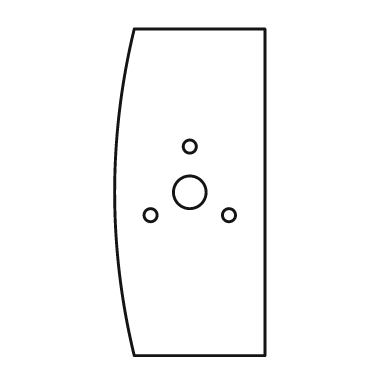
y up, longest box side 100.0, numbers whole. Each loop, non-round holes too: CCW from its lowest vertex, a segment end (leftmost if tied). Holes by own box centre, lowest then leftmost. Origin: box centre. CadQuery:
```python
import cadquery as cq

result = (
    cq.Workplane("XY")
    .moveTo(-17.0, -50.0)
    .lineTo(23.0, -50.0)
    .lineTo(23.0, 50.0)
    .lineTo(-17.0, 50.0)
    .threePointArc((-23.0, 0.0), (-17.0, -50.0))
    .close()
    .moveTo(-12.0, -7.0)
    .circle(2.0)
    .moveTo(12.0, -7.0)
    .circle(2.0)
    .moveTo(0.0, 0.0)
    .circle(5.0)
    .moveTo(0.0, 14.0)
    .circle(2.0)
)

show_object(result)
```